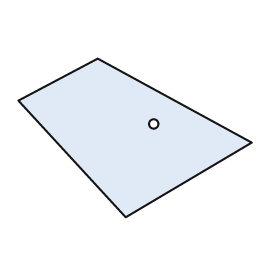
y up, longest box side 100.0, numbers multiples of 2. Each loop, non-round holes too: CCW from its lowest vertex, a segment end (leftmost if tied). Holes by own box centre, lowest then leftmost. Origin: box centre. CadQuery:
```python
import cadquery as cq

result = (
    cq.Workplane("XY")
    .moveTo(-4.0, -34.0)
    .lineTo(50.0, -2.0)
    .lineTo(-16.0, 34.0)
    .lineTo(-50.0, 16.0)
    .close()
    .moveTo(8.0, 6.0)
    .circle(2.0)
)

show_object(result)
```